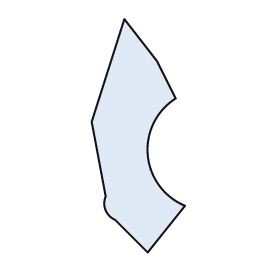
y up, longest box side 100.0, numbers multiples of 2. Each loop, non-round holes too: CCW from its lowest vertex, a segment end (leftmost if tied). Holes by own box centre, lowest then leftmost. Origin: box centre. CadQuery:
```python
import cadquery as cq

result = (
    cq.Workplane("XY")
    .moveTo(4.0, -50.0)
    .lineTo(20.0, -30.0)
    .threePointArc((4.0, -8.0), (16.0, 16.0))
    .lineTo(8.0, 32.0)
    .lineTo(-6.0, 50.0)
    .lineTo(-20.0, 6.0)
    .lineTo(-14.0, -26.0)
    .threePointArc((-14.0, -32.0), (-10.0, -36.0))
    .close()
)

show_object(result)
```